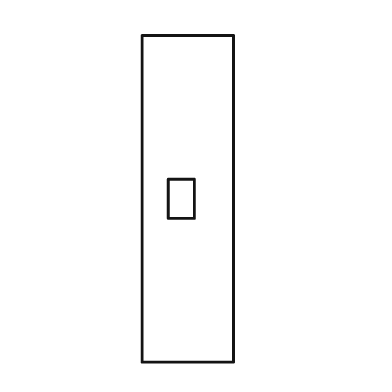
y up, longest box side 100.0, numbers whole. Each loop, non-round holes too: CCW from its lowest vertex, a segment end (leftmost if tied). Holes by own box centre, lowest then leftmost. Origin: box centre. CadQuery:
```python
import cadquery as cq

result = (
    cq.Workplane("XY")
    .moveTo(-14.0, -50.0)
    .lineTo(14.0, -50.0)
    .lineTo(14.0, 50.0)
    .lineTo(-14.0, 50.0)
    .close()
    .moveTo(-6.0, -6.0)
    .lineTo(2.0, -6.0)
    .lineTo(2.0, 6.0)
    .lineTo(-6.0, 6.0)
    .close()
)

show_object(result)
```